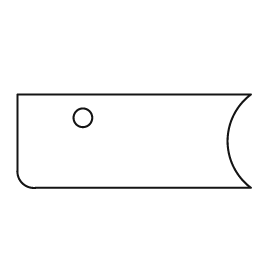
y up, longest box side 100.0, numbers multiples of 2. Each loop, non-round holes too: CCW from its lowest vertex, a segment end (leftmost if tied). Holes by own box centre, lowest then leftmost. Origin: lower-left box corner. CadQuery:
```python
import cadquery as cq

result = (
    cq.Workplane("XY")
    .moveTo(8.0, 0.0)
    .lineTo(100.0, 0.0)
    .threePointArc((90.0, 20.0), (100.0, 40.0))
    .lineTo(0.0, 40.0)
    .lineTo(0.0, 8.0)
    .threePointArc((2.0, 2.0), (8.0, 0.0))
    .close()
    .moveTo(28.0, 30.0)
    .circle(4.0)
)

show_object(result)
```